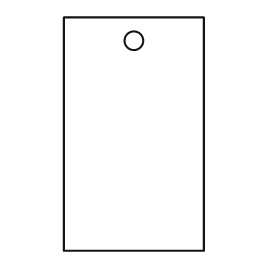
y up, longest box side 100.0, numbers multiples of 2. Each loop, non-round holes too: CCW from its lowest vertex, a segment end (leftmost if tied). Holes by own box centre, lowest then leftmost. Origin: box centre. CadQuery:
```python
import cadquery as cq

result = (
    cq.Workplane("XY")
    .moveTo(-30.0, -50.0)
    .lineTo(30.0, -50.0)
    .lineTo(30.0, 50.0)
    .lineTo(-30.0, 50.0)
    .close()
    .moveTo(0.0, 40.0)
    .circle(4.0)
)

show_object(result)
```